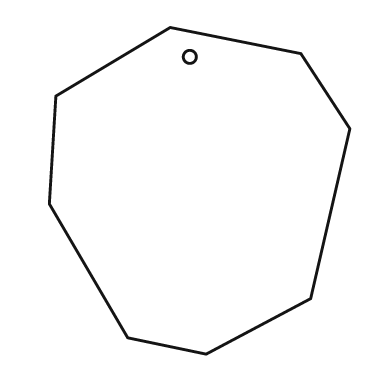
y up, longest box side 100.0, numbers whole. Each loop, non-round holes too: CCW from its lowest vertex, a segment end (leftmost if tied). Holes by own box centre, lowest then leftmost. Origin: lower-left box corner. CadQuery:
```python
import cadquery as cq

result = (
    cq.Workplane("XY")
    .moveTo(48.0, 0.0)
    .lineTo(80.0, 17.0)
    .lineTo(92.0, 69.0)
    .lineTo(77.0, 92.0)
    .lineTo(37.0, 100.0)
    .lineTo(2.0, 79.0)
    .lineTo(0.0, 46.0)
    .lineTo(24.0, 5.0)
    .close()
    .moveTo(43.0, 91.0)
    .circle(2.0)
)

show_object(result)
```